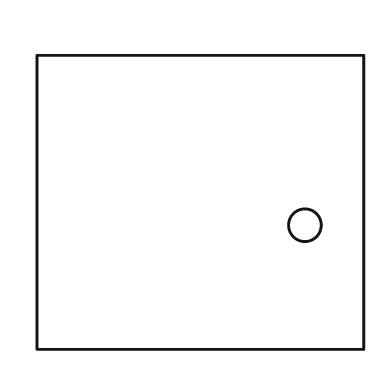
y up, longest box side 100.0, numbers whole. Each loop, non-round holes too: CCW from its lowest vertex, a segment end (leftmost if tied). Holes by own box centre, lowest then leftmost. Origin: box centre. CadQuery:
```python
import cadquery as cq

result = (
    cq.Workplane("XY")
    .moveTo(-50.0, -45.0)
    .lineTo(50.0, -45.0)
    .lineTo(50.0, 45.0)
    .lineTo(-50.0, 45.0)
    .close()
    .moveTo(32.0, -7.0)
    .circle(5.0)
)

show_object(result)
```